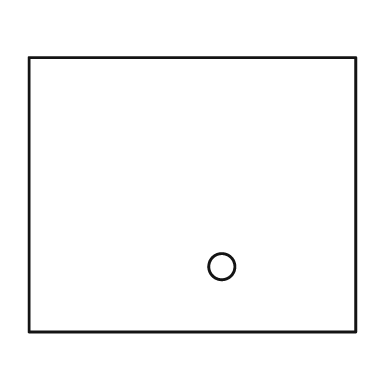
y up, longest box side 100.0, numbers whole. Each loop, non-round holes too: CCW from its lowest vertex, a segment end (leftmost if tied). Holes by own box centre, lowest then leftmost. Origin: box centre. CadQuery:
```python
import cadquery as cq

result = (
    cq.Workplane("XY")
    .moveTo(-50.0, -42.0)
    .lineTo(50.0, -42.0)
    .lineTo(50.0, 42.0)
    .lineTo(-50.0, 42.0)
    .close()
    .moveTo(9.0, -22.0)
    .circle(4.0)
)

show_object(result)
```